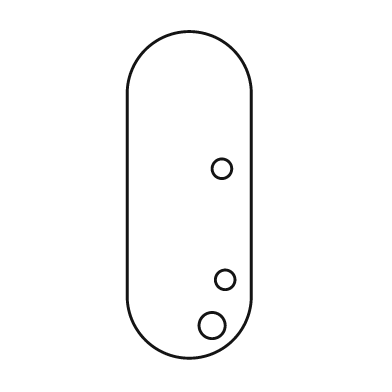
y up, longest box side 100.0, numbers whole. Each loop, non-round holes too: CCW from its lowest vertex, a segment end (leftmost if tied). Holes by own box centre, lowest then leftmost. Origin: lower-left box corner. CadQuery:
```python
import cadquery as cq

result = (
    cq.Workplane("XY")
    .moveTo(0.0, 19.0)
    .threePointArc((19.0, 0.0), (38.0, 19.0))
    .lineTo(38.0, 81.0)
    .threePointArc((19.0, 100.0), (0.0, 81.0))
    .close()
    .moveTo(26.0, 10.0)
    .circle(4.0)
    .moveTo(30.0, 24.0)
    .circle(3.0)
    .moveTo(29.0, 58.0)
    .circle(3.0)
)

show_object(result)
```